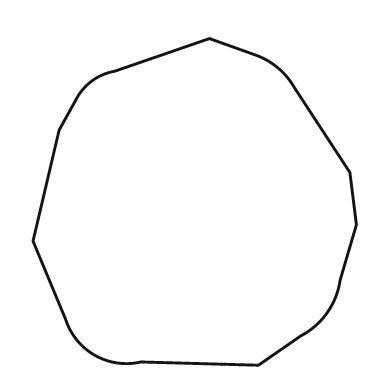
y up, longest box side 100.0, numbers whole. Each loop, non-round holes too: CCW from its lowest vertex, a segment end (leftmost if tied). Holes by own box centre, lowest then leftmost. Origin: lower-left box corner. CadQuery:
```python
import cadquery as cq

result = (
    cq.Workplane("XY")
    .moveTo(69.0, 0.0)
    .lineTo(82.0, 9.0)
    .threePointArc((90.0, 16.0), (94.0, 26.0))
    .lineTo(99.0, 43.0)
    .lineTo(97.0, 59.0)
    .lineTo(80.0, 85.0)
    .threePointArc((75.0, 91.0), (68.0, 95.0))
    .lineTo(54.0, 100.0)
    .lineTo(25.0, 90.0)
    .threePointArc((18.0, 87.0), (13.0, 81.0))
    .lineTo(8.0, 72.0)
    .lineTo(0.0, 38.0)
    .lineTo(10.0, 14.0)
    .threePointArc((19.0, 3.0), (33.0, 1.0))
    .close()
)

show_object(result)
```